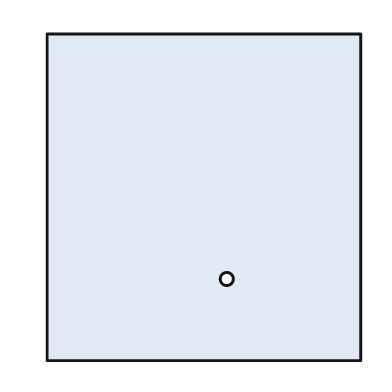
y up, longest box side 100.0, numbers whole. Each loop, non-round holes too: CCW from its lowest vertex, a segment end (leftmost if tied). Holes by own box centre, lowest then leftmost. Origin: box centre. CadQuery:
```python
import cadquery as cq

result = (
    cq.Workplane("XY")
    .moveTo(-48.0, -50.0)
    .lineTo(48.0, -50.0)
    .lineTo(48.0, 50.0)
    .lineTo(-48.0, 50.0)
    .close()
    .moveTo(7.0, -25.0)
    .circle(2.0)
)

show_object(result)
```